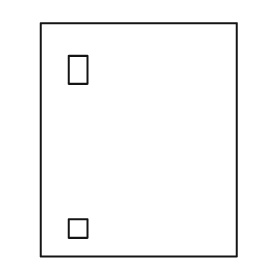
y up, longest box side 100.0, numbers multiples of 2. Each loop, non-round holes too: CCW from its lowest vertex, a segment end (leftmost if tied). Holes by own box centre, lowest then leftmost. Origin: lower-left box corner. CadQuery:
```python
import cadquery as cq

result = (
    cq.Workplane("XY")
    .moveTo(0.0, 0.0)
    .lineTo(84.0, 0.0)
    .lineTo(84.0, 100.0)
    .lineTo(0.0, 100.0)
    .close()
    .moveTo(12.0, 8.0)
    .lineTo(20.0, 8.0)
    .lineTo(20.0, 16.0)
    .lineTo(12.0, 16.0)
    .close()
    .moveTo(12.0, 74.0)
    .lineTo(20.0, 74.0)
    .lineTo(20.0, 86.0)
    .lineTo(12.0, 86.0)
    .close()
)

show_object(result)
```